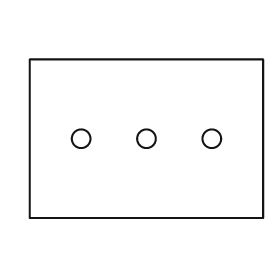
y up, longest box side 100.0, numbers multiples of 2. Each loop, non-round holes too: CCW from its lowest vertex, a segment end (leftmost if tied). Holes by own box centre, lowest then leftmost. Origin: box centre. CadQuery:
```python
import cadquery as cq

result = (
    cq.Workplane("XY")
    .moveTo(-50.0, -34.0)
    .lineTo(50.0, -34.0)
    .lineTo(50.0, 34.0)
    .lineTo(-50.0, 34.0)
    .close()
    .moveTo(-28.0, 0.0)
    .circle(4.0)
    .moveTo(0.0, 0.0)
    .circle(4.0)
    .moveTo(28.0, 0.0)
    .circle(4.0)
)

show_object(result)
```